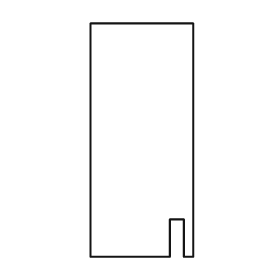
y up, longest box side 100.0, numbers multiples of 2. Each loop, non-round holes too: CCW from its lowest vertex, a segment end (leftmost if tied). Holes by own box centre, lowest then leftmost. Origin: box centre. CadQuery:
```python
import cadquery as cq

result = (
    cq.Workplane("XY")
    .moveTo(-22.0, -50.0)
    .lineTo(12.0, -50.0)
    .lineTo(12.0, -34.0)
    .lineTo(18.0, -34.0)
    .lineTo(18.0, -50.0)
    .lineTo(22.0, -50.0)
    .lineTo(22.0, 50.0)
    .lineTo(-22.0, 50.0)
    .close()
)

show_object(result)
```